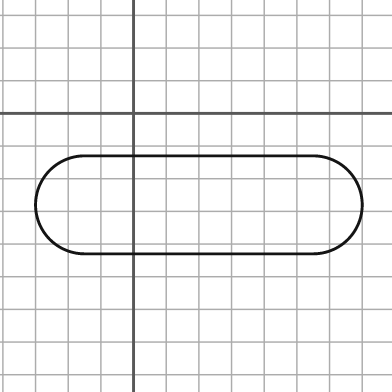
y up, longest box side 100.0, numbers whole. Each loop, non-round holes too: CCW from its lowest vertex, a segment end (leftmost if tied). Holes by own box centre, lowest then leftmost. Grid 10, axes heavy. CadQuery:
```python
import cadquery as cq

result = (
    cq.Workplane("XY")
    .moveTo(-15.0, -43.0)
    .lineTo(55.0, -43.0)
    .threePointArc((70.0, -28.0), (55.0, -13.0))
    .lineTo(-15.0, -13.0)
    .threePointArc((-30.0, -28.0), (-15.0, -43.0))
    .close()
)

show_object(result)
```